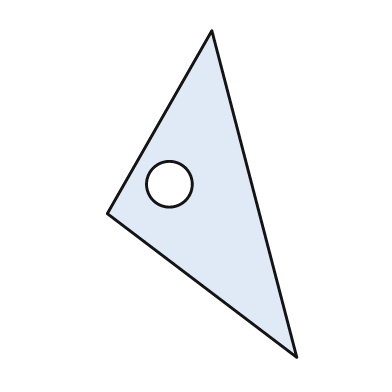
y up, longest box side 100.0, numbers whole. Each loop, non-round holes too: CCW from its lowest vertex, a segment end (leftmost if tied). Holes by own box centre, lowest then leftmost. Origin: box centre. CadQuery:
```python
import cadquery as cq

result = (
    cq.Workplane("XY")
    .moveTo(29.0, -50.0)
    .lineTo(3.0, 50.0)
    .lineTo(-29.0, -6.0)
    .close()
    .moveTo(-10.0, 3.0)
    .circle(7.0)
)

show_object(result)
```